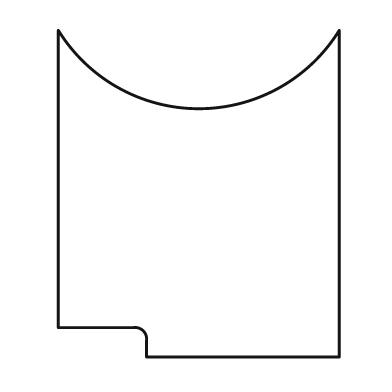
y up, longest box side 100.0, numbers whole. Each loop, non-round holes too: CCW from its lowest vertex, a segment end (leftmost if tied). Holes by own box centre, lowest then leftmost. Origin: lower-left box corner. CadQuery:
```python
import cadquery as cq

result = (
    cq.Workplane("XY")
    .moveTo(27.0, 0.0)
    .lineTo(86.0, 0.0)
    .lineTo(86.0, 100.0)
    .threePointArc((43.0, 76.0), (0.0, 100.0))
    .lineTo(0.0, 9.0)
    .lineTo(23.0, 9.0)
    .threePointArc((26.0, 8.0), (27.0, 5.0))
    .close()
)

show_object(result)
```